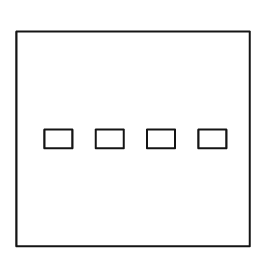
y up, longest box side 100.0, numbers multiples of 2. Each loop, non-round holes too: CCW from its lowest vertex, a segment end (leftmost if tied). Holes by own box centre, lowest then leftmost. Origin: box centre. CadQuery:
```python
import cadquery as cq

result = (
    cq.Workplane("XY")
    .moveTo(-50.0, -46.0)
    .lineTo(50.0, -46.0)
    .lineTo(50.0, 46.0)
    .lineTo(-50.0, 46.0)
    .close()
    .moveTo(-38.0, -4.0)
    .lineTo(-26.0, -4.0)
    .lineTo(-26.0, 4.0)
    .lineTo(-38.0, 4.0)
    .close()
    .moveTo(-16.0, -4.0)
    .lineTo(-4.0, -4.0)
    .lineTo(-4.0, 4.0)
    .lineTo(-16.0, 4.0)
    .close()
    .moveTo(6.0, -4.0)
    .lineTo(18.0, -4.0)
    .lineTo(18.0, 4.0)
    .lineTo(6.0, 4.0)
    .close()
    .moveTo(28.0, -4.0)
    .lineTo(40.0, -4.0)
    .lineTo(40.0, 4.0)
    .lineTo(28.0, 4.0)
    .close()
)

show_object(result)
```